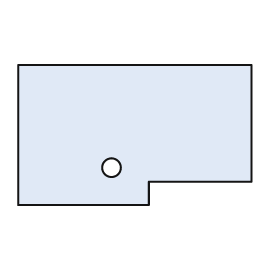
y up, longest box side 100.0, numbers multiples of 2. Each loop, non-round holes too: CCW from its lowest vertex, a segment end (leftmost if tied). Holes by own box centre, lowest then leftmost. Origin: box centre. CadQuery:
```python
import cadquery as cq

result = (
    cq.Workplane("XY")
    .moveTo(-50.0, -30.0)
    .lineTo(6.0, -30.0)
    .lineTo(6.0, -20.0)
    .lineTo(50.0, -20.0)
    .lineTo(50.0, 30.0)
    .lineTo(-50.0, 30.0)
    .close()
    .moveTo(-10.0, -14.0)
    .circle(4.0)
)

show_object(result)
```